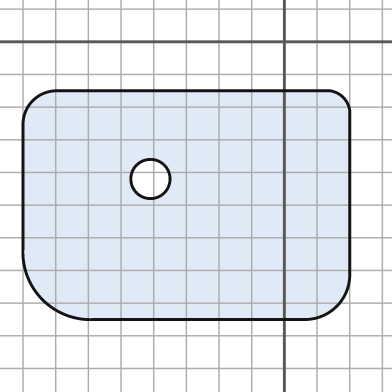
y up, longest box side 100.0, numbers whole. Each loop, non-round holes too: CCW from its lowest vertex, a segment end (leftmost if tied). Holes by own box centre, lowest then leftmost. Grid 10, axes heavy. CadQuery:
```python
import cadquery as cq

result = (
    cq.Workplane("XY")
    .moveTo(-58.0, -85.0)
    .lineTo(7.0, -85.0)
    .threePointArc((16.0, -81.0), (20.0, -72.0))
    .lineTo(20.0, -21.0)
    .threePointArc((18.0, -17.0), (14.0, -15.0))
    .lineTo(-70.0, -15.0)
    .threePointArc((-77.0, -18.0), (-80.0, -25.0))
    .lineTo(-80.0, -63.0)
    .threePointArc((-74.0, -79.0), (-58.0, -85.0))
    .close()
    .moveTo(-41.0, -42.0)
    .circle(6.0)
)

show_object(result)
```